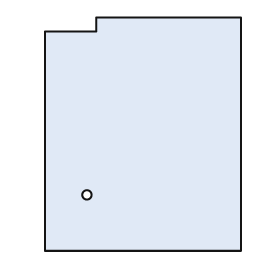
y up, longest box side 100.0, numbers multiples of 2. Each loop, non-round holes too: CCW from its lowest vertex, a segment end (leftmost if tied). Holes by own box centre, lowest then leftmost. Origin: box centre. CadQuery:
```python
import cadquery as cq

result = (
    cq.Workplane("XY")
    .moveTo(-42.0, -50.0)
    .lineTo(42.0, -50.0)
    .lineTo(42.0, 50.0)
    .lineTo(-20.0, 50.0)
    .lineTo(-20.0, 44.0)
    .lineTo(-42.0, 44.0)
    .close()
    .moveTo(-24.0, -26.0)
    .circle(2.0)
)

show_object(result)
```